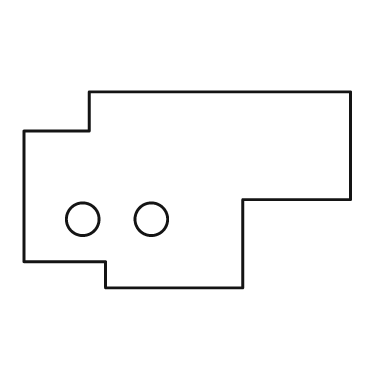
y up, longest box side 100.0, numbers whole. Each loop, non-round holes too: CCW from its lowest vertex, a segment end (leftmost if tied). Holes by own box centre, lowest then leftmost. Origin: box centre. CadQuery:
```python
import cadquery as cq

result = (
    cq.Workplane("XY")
    .moveTo(-25.0, -30.0)
    .lineTo(17.0, -30.0)
    .lineTo(17.0, -3.0)
    .lineTo(50.0, -3.0)
    .lineTo(50.0, 30.0)
    .lineTo(-30.0, 30.0)
    .lineTo(-30.0, 18.0)
    .lineTo(-50.0, 18.0)
    .lineTo(-50.0, -22.0)
    .lineTo(-25.0, -22.0)
    .close()
    .moveTo(-32.0, -9.0)
    .circle(5.0)
    .moveTo(-11.0, -9.0)
    .circle(5.0)
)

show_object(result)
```